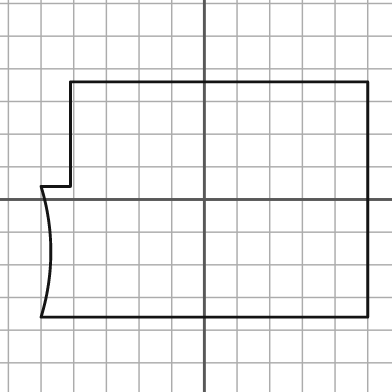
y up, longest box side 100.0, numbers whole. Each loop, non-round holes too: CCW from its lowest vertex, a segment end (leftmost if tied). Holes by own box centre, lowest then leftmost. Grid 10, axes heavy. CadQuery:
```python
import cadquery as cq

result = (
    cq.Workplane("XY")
    .moveTo(-50.0, -36.0)
    .lineTo(50.0, -36.0)
    .lineTo(50.0, 36.0)
    .lineTo(-41.0, 36.0)
    .lineTo(-41.0, 4.0)
    .lineTo(-50.0, 4.0)
    .threePointArc((-47.0, -16.0), (-50.0, -36.0))
    .close()
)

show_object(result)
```